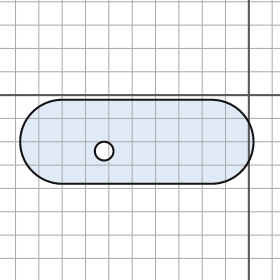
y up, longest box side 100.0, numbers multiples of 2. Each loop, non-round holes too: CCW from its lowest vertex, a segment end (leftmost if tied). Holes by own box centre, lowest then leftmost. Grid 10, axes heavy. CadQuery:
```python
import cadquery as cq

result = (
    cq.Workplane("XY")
    .moveTo(-80.0, -38.0)
    .lineTo(-16.0, -38.0)
    .threePointArc((2.0, -20.0), (-16.0, -2.0))
    .lineTo(-80.0, -2.0)
    .threePointArc((-98.0, -20.0), (-80.0, -38.0))
    .close()
    .moveTo(-62.0, -24.0)
    .circle(4.0)
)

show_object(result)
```